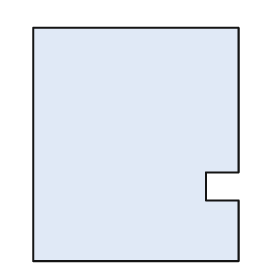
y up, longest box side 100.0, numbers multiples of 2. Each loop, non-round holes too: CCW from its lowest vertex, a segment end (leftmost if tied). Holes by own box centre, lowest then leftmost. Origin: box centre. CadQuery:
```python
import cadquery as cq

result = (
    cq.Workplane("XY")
    .moveTo(-44.0, -50.0)
    .lineTo(44.0, -50.0)
    .lineTo(44.0, -24.0)
    .lineTo(30.0, -24.0)
    .lineTo(30.0, -12.0)
    .lineTo(44.0, -12.0)
    .lineTo(44.0, 50.0)
    .lineTo(-44.0, 50.0)
    .close()
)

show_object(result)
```